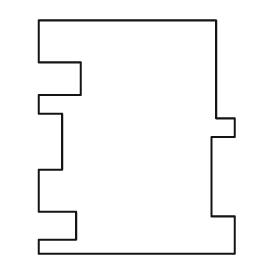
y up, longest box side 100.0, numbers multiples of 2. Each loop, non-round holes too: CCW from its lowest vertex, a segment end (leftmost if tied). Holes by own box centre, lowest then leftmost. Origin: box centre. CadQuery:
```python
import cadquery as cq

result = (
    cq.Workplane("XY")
    .moveTo(-42.0, -50.0)
    .lineTo(42.0, -50.0)
    .lineTo(42.0, -34.0)
    .lineTo(32.0, -34.0)
    .lineTo(32.0, 0.0)
    .lineTo(42.0, 0.0)
    .lineTo(42.0, 8.0)
    .lineTo(34.0, 8.0)
    .lineTo(34.0, 50.0)
    .lineTo(-42.0, 50.0)
    .lineTo(-42.0, 32.0)
    .lineTo(-24.0, 32.0)
    .lineTo(-24.0, 18.0)
    .lineTo(-42.0, 18.0)
    .lineTo(-42.0, 10.0)
    .lineTo(-32.0, 10.0)
    .lineTo(-32.0, -14.0)
    .lineTo(-42.0, -14.0)
    .lineTo(-42.0, -32.0)
    .lineTo(-26.0, -32.0)
    .lineTo(-26.0, -44.0)
    .lineTo(-42.0, -44.0)
    .close()
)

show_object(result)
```